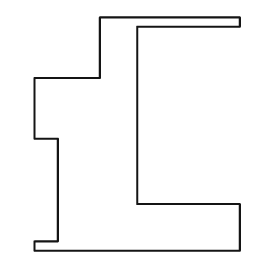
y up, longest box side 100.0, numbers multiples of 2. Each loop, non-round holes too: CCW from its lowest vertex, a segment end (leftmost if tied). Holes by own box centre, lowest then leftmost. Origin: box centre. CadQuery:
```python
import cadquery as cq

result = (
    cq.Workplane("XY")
    .moveTo(-44.0, -50.0)
    .lineTo(44.0, -50.0)
    .lineTo(44.0, -30.0)
    .lineTo(0.0, -30.0)
    .lineTo(0.0, 46.0)
    .lineTo(44.0, 46.0)
    .lineTo(44.0, 50.0)
    .lineTo(-16.0, 50.0)
    .lineTo(-16.0, 24.0)
    .lineTo(-44.0, 24.0)
    .lineTo(-44.0, -2.0)
    .lineTo(-34.0, -2.0)
    .lineTo(-34.0, -46.0)
    .lineTo(-44.0, -46.0)
    .close()
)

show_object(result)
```